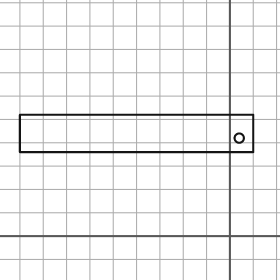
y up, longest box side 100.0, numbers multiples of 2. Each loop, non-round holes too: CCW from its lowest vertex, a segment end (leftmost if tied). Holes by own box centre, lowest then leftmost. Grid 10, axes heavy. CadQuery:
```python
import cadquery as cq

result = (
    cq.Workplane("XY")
    .moveTo(-90.0, 36.0)
    .lineTo(10.0, 36.0)
    .lineTo(10.0, 52.0)
    .lineTo(-90.0, 52.0)
    .close()
    .moveTo(4.0, 42.0)
    .circle(2.0)
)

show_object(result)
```